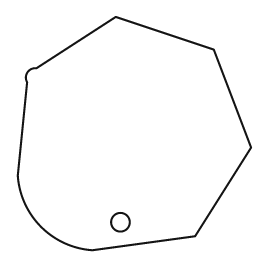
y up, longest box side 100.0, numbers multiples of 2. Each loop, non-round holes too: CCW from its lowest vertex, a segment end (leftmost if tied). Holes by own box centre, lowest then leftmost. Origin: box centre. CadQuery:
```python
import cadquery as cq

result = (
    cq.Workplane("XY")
    .moveTo(-18.0, -50.0)
    .lineTo(26.0, -44.0)
    .lineTo(50.0, -6.0)
    .lineTo(34.0, 36.0)
    .lineTo(-8.0, 50.0)
    .lineTo(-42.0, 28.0)
    .threePointArc((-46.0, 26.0), (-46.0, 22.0))
    .lineTo(-50.0, -18.0)
    .threePointArc((-40.0, -40.0), (-18.0, -50.0))
    .close()
    .moveTo(-6.0, -38.0)
    .circle(4.0)
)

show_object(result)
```